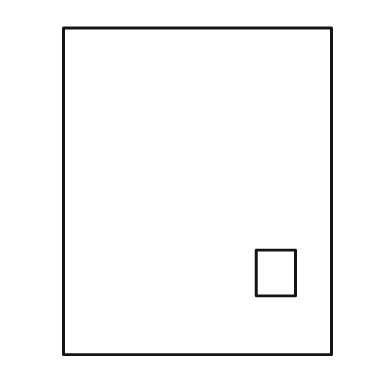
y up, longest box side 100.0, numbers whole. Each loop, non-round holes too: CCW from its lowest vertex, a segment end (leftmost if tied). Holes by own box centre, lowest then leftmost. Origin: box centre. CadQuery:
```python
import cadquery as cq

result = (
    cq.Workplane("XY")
    .moveTo(-41.0, -50.0)
    .lineTo(41.0, -50.0)
    .lineTo(41.0, 50.0)
    .lineTo(-41.0, 50.0)
    .close()
    .moveTo(18.0, -32.0)
    .lineTo(30.0, -32.0)
    .lineTo(30.0, -18.0)
    .lineTo(18.0, -18.0)
    .close()
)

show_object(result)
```